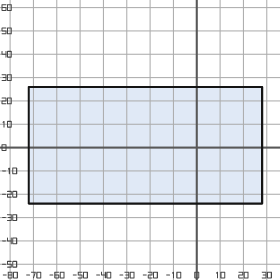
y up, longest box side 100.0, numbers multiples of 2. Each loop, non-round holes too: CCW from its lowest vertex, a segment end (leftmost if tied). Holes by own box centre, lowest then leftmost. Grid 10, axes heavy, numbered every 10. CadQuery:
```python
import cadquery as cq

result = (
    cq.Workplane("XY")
    .moveTo(-72.0, -24.0)
    .lineTo(28.0, -24.0)
    .lineTo(28.0, 26.0)
    .lineTo(-72.0, 26.0)
    .close()
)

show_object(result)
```